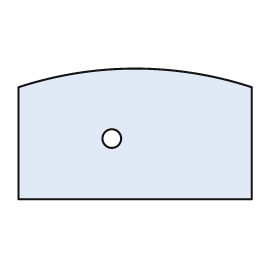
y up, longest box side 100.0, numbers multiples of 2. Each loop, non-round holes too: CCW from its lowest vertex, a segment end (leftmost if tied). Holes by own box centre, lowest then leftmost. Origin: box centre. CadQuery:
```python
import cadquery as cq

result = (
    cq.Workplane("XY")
    .moveTo(-50.0, -28.0)
    .lineTo(50.0, -28.0)
    .lineTo(50.0, 20.0)
    .threePointArc((0.0, 28.0), (-50.0, 20.0))
    .close()
    .moveTo(-10.0, -2.0)
    .circle(4.0)
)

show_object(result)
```